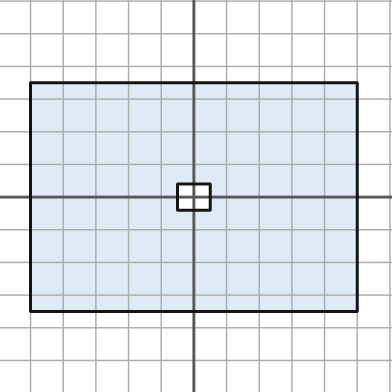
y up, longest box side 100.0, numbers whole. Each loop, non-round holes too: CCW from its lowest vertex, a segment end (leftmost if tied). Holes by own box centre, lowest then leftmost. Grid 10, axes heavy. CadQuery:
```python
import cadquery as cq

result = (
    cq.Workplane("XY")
    .moveTo(-50.0, -35.0)
    .lineTo(50.0, -35.0)
    .lineTo(50.0, 35.0)
    .lineTo(-50.0, 35.0)
    .close()
    .moveTo(-5.0, -4.0)
    .lineTo(5.0, -4.0)
    .lineTo(5.0, 4.0)
    .lineTo(-5.0, 4.0)
    .close()
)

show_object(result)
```